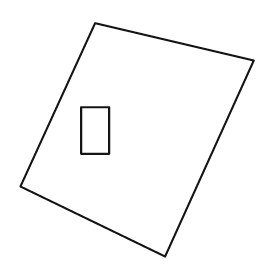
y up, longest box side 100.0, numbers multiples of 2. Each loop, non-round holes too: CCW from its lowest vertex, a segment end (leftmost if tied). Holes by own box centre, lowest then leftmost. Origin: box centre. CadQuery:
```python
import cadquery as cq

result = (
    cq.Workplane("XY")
    .moveTo(12.0, -50.0)
    .lineTo(50.0, 34.0)
    .lineTo(-18.0, 50.0)
    .lineTo(-50.0, -20.0)
    .close()
    .moveTo(-24.0, -6.0)
    .lineTo(-12.0, -6.0)
    .lineTo(-12.0, 14.0)
    .lineTo(-24.0, 14.0)
    .close()
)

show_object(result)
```